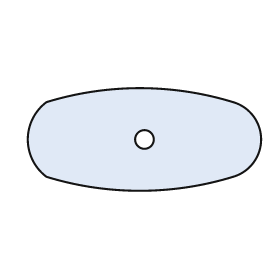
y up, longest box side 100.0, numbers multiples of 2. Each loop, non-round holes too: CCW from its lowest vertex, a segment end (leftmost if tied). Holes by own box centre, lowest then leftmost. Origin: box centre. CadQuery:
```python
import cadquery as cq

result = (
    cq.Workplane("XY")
    .moveTo(-42.0, -16.0)
    .threePointArc((-2.0, -22.0), (38.0, -16.0))
    .threePointArc((50.0, 0.0), (38.0, 16.0))
    .threePointArc((-2.0, 22.0), (-42.0, 16.0))
    .threePointArc((-50.0, 0.0), (-42.0, -16.0))
    .close()
    .moveTo(0.0, 0.0)
    .circle(4.0)
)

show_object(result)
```